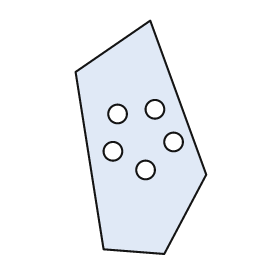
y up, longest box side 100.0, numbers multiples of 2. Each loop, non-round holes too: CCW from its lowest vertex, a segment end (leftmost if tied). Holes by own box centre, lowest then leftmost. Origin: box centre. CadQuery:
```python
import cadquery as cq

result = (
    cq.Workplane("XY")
    .moveTo(10.0, -50.0)
    .lineTo(28.0, -16.0)
    .lineTo(4.0, 50.0)
    .lineTo(-28.0, 28.0)
    .lineTo(-16.0, -48.0)
    .close()
    .moveTo(2.0, -14.0)
    .circle(4.0)
    .moveTo(-12.0, -6.0)
    .circle(4.0)
    .moveTo(14.0, -2.0)
    .circle(4.0)
    .moveTo(-10.0, 10.0)
    .circle(4.0)
    .moveTo(6.0, 12.0)
    .circle(4.0)
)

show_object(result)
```